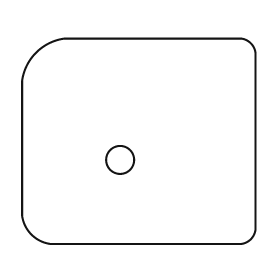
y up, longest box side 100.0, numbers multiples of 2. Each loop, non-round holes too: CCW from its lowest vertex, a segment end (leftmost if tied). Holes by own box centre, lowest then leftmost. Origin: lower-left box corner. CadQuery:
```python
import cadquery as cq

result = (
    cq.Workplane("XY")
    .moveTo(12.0, 0.0)
    .lineTo(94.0, 0.0)
    .threePointArc((98.0, 2.0), (100.0, 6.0))
    .lineTo(100.0, 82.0)
    .threePointArc((98.0, 86.0), (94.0, 88.0))
    .lineTo(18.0, 88.0)
    .threePointArc((6.0, 82.0), (0.0, 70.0))
    .lineTo(0.0, 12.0)
    .threePointArc((4.0, 4.0), (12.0, 0.0))
    .close()
    .moveTo(42.0, 36.0)
    .circle(6.0)
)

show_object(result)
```